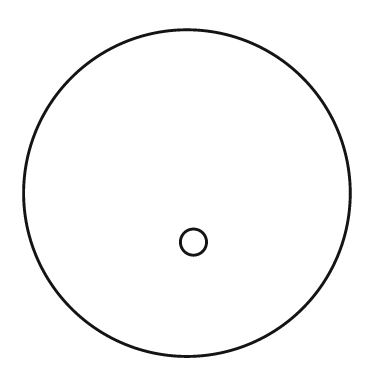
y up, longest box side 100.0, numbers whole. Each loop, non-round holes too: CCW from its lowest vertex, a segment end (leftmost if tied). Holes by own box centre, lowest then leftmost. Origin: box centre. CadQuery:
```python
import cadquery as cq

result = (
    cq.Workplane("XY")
    .moveTo(0.0, 0.0)
    .circle(50.0)
    .moveTo(2.0, -15.0)
    .circle(4.0)
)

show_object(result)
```